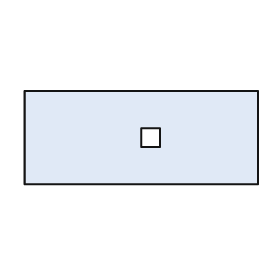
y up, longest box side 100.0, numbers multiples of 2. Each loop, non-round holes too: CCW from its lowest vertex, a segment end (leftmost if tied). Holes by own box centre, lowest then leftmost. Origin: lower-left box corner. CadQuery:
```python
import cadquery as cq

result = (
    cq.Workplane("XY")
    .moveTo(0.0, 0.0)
    .lineTo(100.0, 0.0)
    .lineTo(100.0, 40.0)
    .lineTo(0.0, 40.0)
    .close()
    .moveTo(50.0, 16.0)
    .lineTo(58.0, 16.0)
    .lineTo(58.0, 24.0)
    .lineTo(50.0, 24.0)
    .close()
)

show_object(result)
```